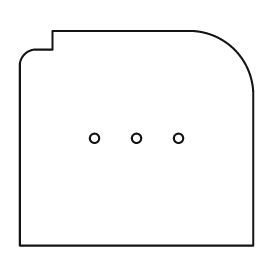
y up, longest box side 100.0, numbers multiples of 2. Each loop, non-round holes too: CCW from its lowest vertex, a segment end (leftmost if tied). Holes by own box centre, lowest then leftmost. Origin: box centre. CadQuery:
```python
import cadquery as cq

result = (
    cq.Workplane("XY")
    .moveTo(-50.0, -46.0)
    .lineTo(50.0, -46.0)
    .lineTo(50.0, 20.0)
    .threePointArc((42.0, 38.0), (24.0, 46.0))
    .lineTo(-36.0, 46.0)
    .lineTo(-36.0, 38.0)
    .lineTo(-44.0, 38.0)
    .threePointArc((-48.0, 36.0), (-50.0, 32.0))
    .close()
    .moveTo(-18.0, 0.0)
    .circle(2.0)
    .moveTo(0.0, 0.0)
    .circle(2.0)
    .moveTo(18.0, 0.0)
    .circle(2.0)
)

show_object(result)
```